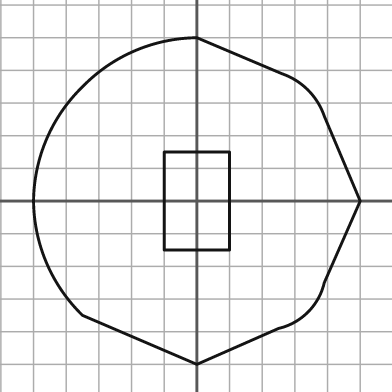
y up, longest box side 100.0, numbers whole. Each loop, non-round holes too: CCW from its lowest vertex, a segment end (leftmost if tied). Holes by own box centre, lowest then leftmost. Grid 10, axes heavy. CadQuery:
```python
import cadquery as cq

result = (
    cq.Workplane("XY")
    .moveTo(0.0, -50.0)
    .lineTo(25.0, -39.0)
    .threePointArc((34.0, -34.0), (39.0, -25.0))
    .lineTo(50.0, 0.0)
    .lineTo(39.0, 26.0)
    .threePointArc((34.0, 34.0), (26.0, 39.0))
    .lineTo(0.0, 50.0)
    .threePointArc((-19.0, 46.0), (-35.0, 35.0))
    .threePointArc((-46.0, 19.0), (-50.0, 0.0))
    .threePointArc((-46.0, -19.0), (-35.0, -35.0))
    .close()
    .moveTo(-10.0, -15.0)
    .lineTo(10.0, -15.0)
    .lineTo(10.0, 15.0)
    .lineTo(-10.0, 15.0)
    .close()
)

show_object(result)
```